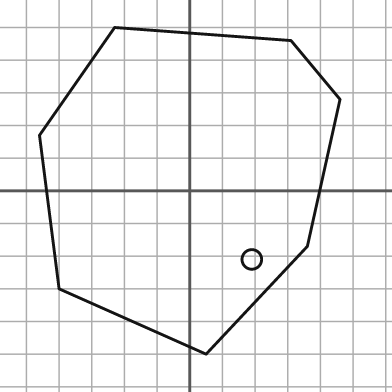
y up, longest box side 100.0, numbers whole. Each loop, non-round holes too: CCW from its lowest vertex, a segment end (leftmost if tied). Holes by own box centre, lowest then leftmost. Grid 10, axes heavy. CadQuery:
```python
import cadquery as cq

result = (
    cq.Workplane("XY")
    .moveTo(5.0, -50.0)
    .lineTo(36.0, -17.0)
    .lineTo(46.0, 28.0)
    .lineTo(31.0, 46.0)
    .lineTo(-23.0, 50.0)
    .lineTo(-46.0, 17.0)
    .lineTo(-40.0, -30.0)
    .close()
    .moveTo(19.0, -21.0)
    .circle(3.0)
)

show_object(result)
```